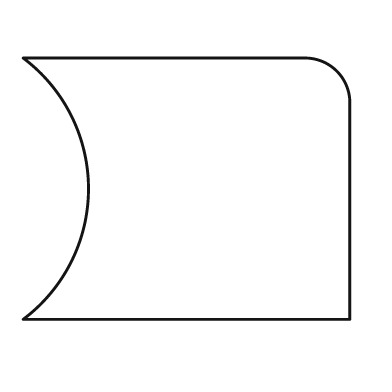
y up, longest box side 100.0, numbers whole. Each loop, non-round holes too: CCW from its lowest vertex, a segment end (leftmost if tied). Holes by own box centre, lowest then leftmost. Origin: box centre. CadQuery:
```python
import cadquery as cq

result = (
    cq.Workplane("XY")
    .moveTo(-50.0, -40.0)
    .lineTo(50.0, -40.0)
    .lineTo(50.0, 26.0)
    .threePointArc((46.0, 36.0), (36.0, 40.0))
    .lineTo(-50.0, 40.0)
    .threePointArc((-30.0, 0.0), (-50.0, -40.0))
    .close()
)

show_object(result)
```